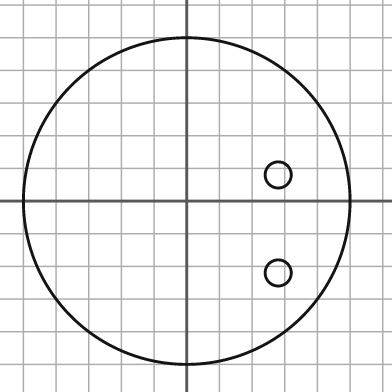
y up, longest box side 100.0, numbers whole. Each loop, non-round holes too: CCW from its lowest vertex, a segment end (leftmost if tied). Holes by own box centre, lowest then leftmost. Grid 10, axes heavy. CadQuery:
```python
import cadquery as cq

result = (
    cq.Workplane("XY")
    .moveTo(0.0, 0.0)
    .circle(50.0)
    .moveTo(28.0, -22.0)
    .circle(4.0)
    .moveTo(28.0, 8.0)
    .circle(4.0)
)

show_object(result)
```